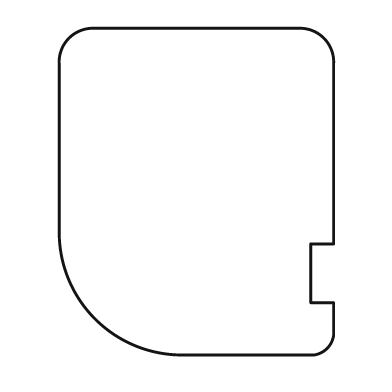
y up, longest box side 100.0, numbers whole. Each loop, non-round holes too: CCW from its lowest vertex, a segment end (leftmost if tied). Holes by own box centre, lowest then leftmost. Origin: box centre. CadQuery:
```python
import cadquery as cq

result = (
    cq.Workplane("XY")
    .moveTo(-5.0, -50.0)
    .lineTo(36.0, -50.0)
    .threePointArc((40.0, -48.0), (42.0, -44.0))
    .lineTo(42.0, -34.0)
    .lineTo(35.0, -34.0)
    .lineTo(35.0, -16.0)
    .lineTo(42.0, -16.0)
    .lineTo(42.0, 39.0)
    .threePointArc((39.0, 47.0), (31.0, 50.0))
    .lineTo(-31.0, 50.0)
    .threePointArc((-39.0, 47.0), (-42.0, 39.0))
    .lineTo(-42.0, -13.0)
    .threePointArc((-31.0, -39.0), (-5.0, -50.0))
    .close()
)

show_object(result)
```